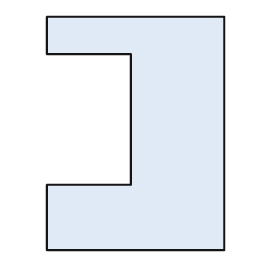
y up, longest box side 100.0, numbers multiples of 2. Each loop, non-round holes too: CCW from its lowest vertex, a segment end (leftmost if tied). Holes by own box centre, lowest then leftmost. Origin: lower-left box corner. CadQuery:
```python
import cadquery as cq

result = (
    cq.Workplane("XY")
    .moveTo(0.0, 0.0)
    .lineTo(76.0, 0.0)
    .lineTo(76.0, 100.0)
    .lineTo(0.0, 100.0)
    .lineTo(0.0, 84.0)
    .lineTo(36.0, 84.0)
    .lineTo(36.0, 28.0)
    .lineTo(0.0, 28.0)
    .close()
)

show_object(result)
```